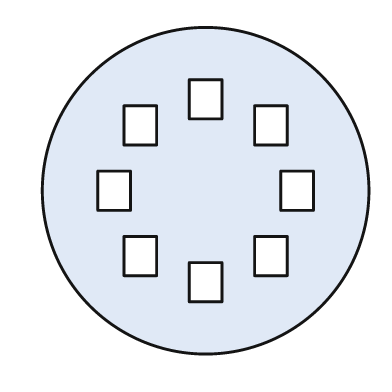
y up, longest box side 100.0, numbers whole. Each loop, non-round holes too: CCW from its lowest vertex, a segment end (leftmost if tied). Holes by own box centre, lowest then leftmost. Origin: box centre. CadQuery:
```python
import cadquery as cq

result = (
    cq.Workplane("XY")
    .moveTo(0.0, 0.0)
    .circle(50.0)
    .moveTo(-5.0, -34.0)
    .lineTo(5.0, -34.0)
    .lineTo(5.0, -22.0)
    .lineTo(-5.0, -22.0)
    .close()
    .moveTo(-25.0, -26.0)
    .lineTo(-15.0, -26.0)
    .lineTo(-15.0, -14.0)
    .lineTo(-25.0, -14.0)
    .close()
    .moveTo(15.0, -26.0)
    .lineTo(25.0, -26.0)
    .lineTo(25.0, -14.0)
    .lineTo(15.0, -14.0)
    .close()
    .moveTo(-33.0, -6.0)
    .lineTo(-23.0, -6.0)
    .lineTo(-23.0, 6.0)
    .lineTo(-33.0, 6.0)
    .close()
    .moveTo(23.0, -6.0)
    .lineTo(33.0, -6.0)
    .lineTo(33.0, 6.0)
    .lineTo(23.0, 6.0)
    .close()
    .moveTo(-25.0, 14.0)
    .lineTo(-15.0, 14.0)
    .lineTo(-15.0, 26.0)
    .lineTo(-25.0, 26.0)
    .close()
    .moveTo(15.0, 14.0)
    .lineTo(25.0, 14.0)
    .lineTo(25.0, 26.0)
    .lineTo(15.0, 26.0)
    .close()
    .moveTo(-5.0, 22.0)
    .lineTo(5.0, 22.0)
    .lineTo(5.0, 34.0)
    .lineTo(-5.0, 34.0)
    .close()
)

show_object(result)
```